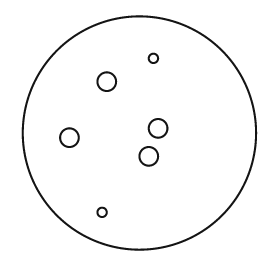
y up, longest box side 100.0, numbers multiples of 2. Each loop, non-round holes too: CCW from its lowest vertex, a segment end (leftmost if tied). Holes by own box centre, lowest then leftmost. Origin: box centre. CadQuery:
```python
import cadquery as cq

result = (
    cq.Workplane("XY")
    .moveTo(0.0, 0.0)
    .circle(50.0)
    .moveTo(-16.0, -34.0)
    .circle(2.0)
    .moveTo(4.0, -10.0)
    .circle(4.0)
    .moveTo(-30.0, -2.0)
    .circle(4.0)
    .moveTo(8.0, 2.0)
    .circle(4.0)
    .moveTo(-14.0, 22.0)
    .circle(4.0)
    .moveTo(6.0, 32.0)
    .circle(2.0)
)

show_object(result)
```